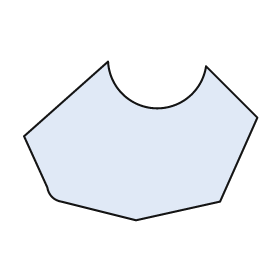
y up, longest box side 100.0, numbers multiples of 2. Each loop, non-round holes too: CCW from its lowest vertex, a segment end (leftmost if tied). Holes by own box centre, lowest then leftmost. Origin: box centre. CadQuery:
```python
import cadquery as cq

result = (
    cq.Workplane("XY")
    .moveTo(-2.0, -34.0)
    .lineTo(34.0, -26.0)
    .lineTo(50.0, 10.0)
    .lineTo(28.0, 32.0)
    .threePointArc((6.0, 14.0), (-14.0, 34.0))
    .lineTo(-50.0, 2.0)
    .lineTo(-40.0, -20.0)
    .threePointArc((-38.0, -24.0), (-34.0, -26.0))
    .close()
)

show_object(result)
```